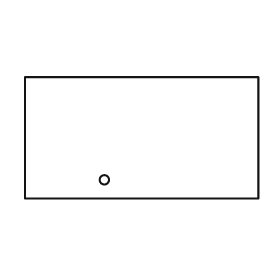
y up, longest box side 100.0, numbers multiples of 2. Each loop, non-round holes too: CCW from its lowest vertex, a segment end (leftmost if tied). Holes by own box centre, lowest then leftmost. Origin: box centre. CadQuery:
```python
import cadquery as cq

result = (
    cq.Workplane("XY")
    .moveTo(-50.0, -26.0)
    .lineTo(50.0, -26.0)
    .lineTo(50.0, 26.0)
    .lineTo(-50.0, 26.0)
    .close()
    .moveTo(-16.0, -18.0)
    .circle(2.0)
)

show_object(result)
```